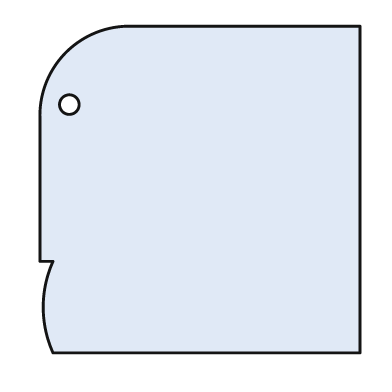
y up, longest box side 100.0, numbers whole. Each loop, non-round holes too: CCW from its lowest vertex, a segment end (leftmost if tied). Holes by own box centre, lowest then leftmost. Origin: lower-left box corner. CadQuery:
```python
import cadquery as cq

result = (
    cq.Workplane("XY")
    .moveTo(4.0, 0.0)
    .lineTo(98.0, 0.0)
    .lineTo(98.0, 100.0)
    .lineTo(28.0, 100.0)
    .threePointArc((8.0, 92.0), (0.0, 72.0))
    .lineTo(0.0, 28.0)
    .lineTo(4.0, 28.0)
    .threePointArc((1.0, 14.0), (4.0, 0.0))
    .close()
    .moveTo(9.0, 76.0)
    .circle(3.0)
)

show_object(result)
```